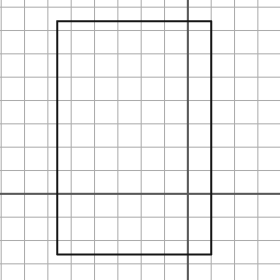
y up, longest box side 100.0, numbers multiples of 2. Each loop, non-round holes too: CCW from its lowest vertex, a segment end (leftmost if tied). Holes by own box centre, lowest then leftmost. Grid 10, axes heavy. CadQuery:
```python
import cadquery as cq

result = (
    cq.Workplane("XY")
    .moveTo(-56.0, -26.0)
    .lineTo(10.0, -26.0)
    .lineTo(10.0, 74.0)
    .lineTo(-56.0, 74.0)
    .close()
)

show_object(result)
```